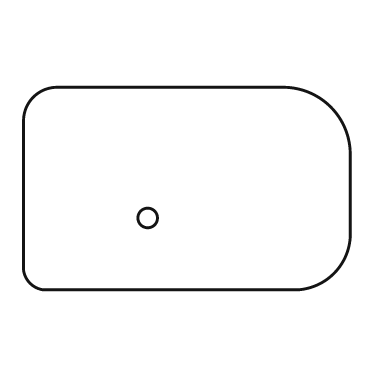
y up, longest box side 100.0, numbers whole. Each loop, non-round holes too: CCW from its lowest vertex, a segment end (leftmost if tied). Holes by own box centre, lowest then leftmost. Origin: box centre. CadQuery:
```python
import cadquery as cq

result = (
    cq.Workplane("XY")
    .moveTo(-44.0, -31.0)
    .lineTo(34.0, -31.0)
    .threePointArc((45.0, -26.0), (50.0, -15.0))
    .lineTo(50.0, 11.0)
    .threePointArc((44.0, 25.0), (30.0, 31.0))
    .lineTo(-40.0, 31.0)
    .threePointArc((-47.0, 28.0), (-50.0, 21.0))
    .lineTo(-50.0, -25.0)
    .threePointArc((-48.0, -29.0), (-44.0, -31.0))
    .close()
    .moveTo(-12.0, -9.0)
    .circle(3.0)
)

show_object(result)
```